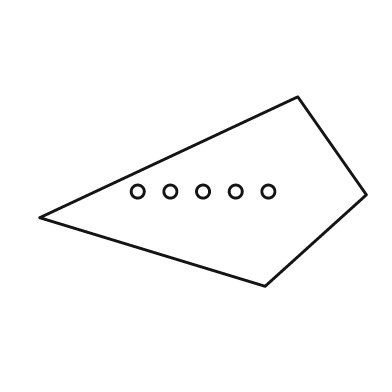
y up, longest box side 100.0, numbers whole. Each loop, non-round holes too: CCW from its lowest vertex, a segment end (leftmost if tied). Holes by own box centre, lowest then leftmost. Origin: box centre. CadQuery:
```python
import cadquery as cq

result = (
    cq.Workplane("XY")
    .moveTo(19.0, -29.0)
    .lineTo(50.0, -1.0)
    .lineTo(29.0, 29.0)
    .lineTo(-50.0, -8.0)
    .close()
    .moveTo(-20.0, 0.0)
    .circle(2.0)
    .moveTo(-10.0, 0.0)
    .circle(2.0)
    .moveTo(0.0, 0.0)
    .circle(2.0)
    .moveTo(10.0, 0.0)
    .circle(2.0)
    .moveTo(20.0, 0.0)
    .circle(2.0)
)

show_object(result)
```